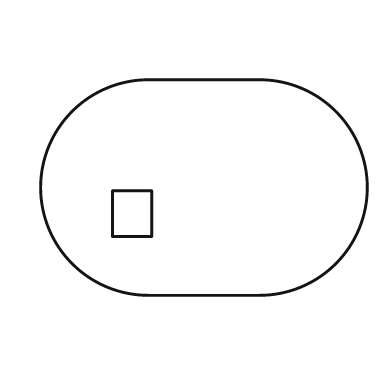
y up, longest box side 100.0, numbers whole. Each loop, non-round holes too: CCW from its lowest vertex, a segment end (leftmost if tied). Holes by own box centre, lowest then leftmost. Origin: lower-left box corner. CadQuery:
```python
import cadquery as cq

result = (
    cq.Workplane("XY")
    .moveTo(33.0, 0.0)
    .lineTo(67.0, 0.0)
    .threePointArc((100.0, 33.0), (67.0, 66.0))
    .lineTo(33.0, 66.0)
    .threePointArc((0.0, 33.0), (33.0, 0.0))
    .close()
    .moveTo(22.0, 18.0)
    .lineTo(34.0, 18.0)
    .lineTo(34.0, 32.0)
    .lineTo(22.0, 32.0)
    .close()
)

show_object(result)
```